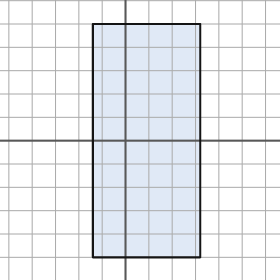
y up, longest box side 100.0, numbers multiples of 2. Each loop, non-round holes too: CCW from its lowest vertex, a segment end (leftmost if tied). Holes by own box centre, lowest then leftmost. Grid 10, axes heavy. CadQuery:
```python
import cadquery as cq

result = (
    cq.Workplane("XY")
    .moveTo(-14.0, -50.0)
    .lineTo(32.0, -50.0)
    .lineTo(32.0, 50.0)
    .lineTo(-14.0, 50.0)
    .close()
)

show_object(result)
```